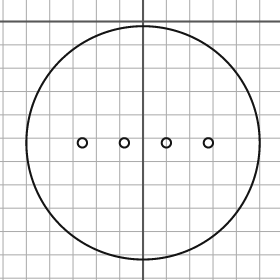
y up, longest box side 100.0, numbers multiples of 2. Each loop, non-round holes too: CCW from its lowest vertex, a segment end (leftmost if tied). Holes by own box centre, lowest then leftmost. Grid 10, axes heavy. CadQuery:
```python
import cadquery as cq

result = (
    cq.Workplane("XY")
    .moveTo(0.0, -52.0)
    .circle(50.0)
    .moveTo(-26.0, -52.0)
    .circle(2.0)
    .moveTo(-8.0, -52.0)
    .circle(2.0)
    .moveTo(10.0, -52.0)
    .circle(2.0)
    .moveTo(28.0, -52.0)
    .circle(2.0)
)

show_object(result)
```